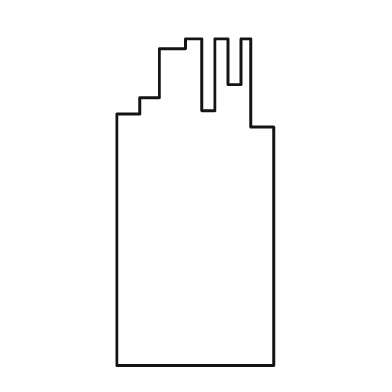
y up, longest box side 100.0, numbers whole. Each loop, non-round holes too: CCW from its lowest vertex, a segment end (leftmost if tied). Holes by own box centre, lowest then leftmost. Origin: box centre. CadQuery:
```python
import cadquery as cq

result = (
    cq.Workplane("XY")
    .moveTo(-24.0, -50.0)
    .lineTo(24.0, -50.0)
    .lineTo(24.0, 23.0)
    .lineTo(17.0, 23.0)
    .lineTo(17.0, 50.0)
    .lineTo(14.0, 50.0)
    .lineTo(14.0, 36.0)
    .lineTo(10.0, 36.0)
    .lineTo(10.0, 50.0)
    .lineTo(6.0, 50.0)
    .lineTo(6.0, 28.0)
    .lineTo(2.0, 28.0)
    .lineTo(2.0, 50.0)
    .lineTo(-3.0, 50.0)
    .lineTo(-3.0, 47.0)
    .lineTo(-11.0, 47.0)
    .lineTo(-11.0, 32.0)
    .lineTo(-17.0, 32.0)
    .lineTo(-17.0, 27.0)
    .lineTo(-24.0, 27.0)
    .close()
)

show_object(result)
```